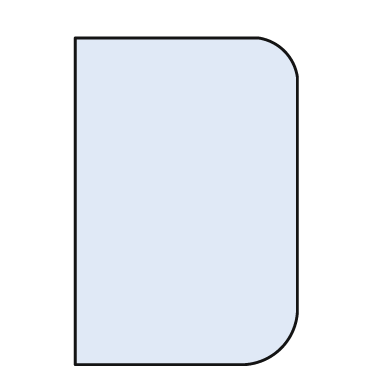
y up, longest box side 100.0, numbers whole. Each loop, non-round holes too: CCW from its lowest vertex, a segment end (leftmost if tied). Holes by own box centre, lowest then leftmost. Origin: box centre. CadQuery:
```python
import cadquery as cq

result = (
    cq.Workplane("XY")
    .moveTo(-34.0, -50.0)
    .lineTo(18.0, -50.0)
    .threePointArc((29.0, -45.0), (34.0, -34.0))
    .lineTo(34.0, 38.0)
    .threePointArc((30.0, 46.0), (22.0, 50.0))
    .lineTo(-34.0, 50.0)
    .close()
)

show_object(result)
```